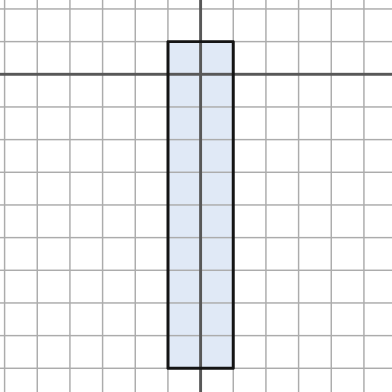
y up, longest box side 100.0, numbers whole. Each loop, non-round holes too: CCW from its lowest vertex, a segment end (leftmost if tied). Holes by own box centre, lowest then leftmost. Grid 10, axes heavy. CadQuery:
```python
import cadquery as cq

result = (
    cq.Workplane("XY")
    .moveTo(-10.0, -90.0)
    .lineTo(10.0, -90.0)
    .lineTo(10.0, 10.0)
    .lineTo(-10.0, 10.0)
    .close()
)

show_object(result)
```